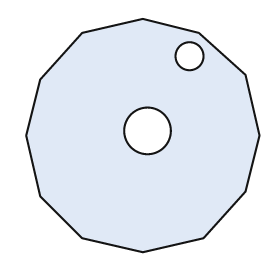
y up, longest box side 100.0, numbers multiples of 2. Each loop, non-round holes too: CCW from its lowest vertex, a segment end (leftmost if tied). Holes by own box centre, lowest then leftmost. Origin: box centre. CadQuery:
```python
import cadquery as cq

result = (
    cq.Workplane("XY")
    .moveTo(0.0, -50.0)
    .lineTo(26.0, -44.0)
    .lineTo(44.0, -24.0)
    .lineTo(50.0, 0.0)
    .lineTo(44.0, 26.0)
    .lineTo(24.0, 44.0)
    .lineTo(0.0, 50.0)
    .lineTo(-26.0, 44.0)
    .lineTo(-44.0, 24.0)
    .lineTo(-50.0, 0.0)
    .lineTo(-44.0, -26.0)
    .lineTo(-26.0, -44.0)
    .close()
    .moveTo(2.0, 2.0)
    .circle(10.0)
    .moveTo(20.0, 34.0)
    .circle(6.0)
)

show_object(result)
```